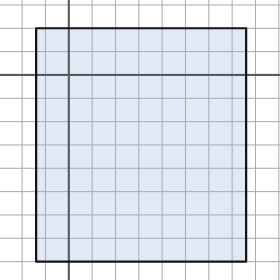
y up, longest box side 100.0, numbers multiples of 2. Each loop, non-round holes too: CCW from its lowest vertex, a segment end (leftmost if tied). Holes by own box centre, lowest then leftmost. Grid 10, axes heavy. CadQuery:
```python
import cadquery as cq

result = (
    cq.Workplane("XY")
    .moveTo(-14.0, -80.0)
    .lineTo(76.0, -80.0)
    .lineTo(76.0, 20.0)
    .lineTo(-14.0, 20.0)
    .close()
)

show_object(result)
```